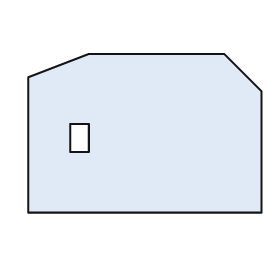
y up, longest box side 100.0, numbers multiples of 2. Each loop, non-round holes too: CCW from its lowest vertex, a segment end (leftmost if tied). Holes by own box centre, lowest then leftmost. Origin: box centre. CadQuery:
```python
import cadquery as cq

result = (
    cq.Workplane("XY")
    .moveTo(-50.0, -34.0)
    .lineTo(50.0, -34.0)
    .lineTo(50.0, 18.0)
    .lineTo(34.0, 34.0)
    .lineTo(-24.0, 34.0)
    .lineTo(-50.0, 24.0)
    .close()
    .moveTo(-32.0, -8.0)
    .lineTo(-24.0, -8.0)
    .lineTo(-24.0, 4.0)
    .lineTo(-32.0, 4.0)
    .close()
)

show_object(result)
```